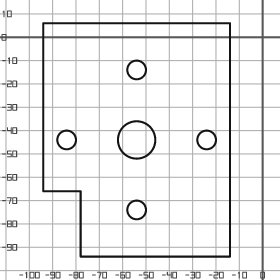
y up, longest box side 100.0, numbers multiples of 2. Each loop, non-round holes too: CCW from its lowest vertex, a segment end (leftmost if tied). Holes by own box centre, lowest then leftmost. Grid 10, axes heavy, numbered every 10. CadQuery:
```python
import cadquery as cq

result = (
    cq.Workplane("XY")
    .moveTo(-78.0, -94.0)
    .lineTo(-14.0, -94.0)
    .lineTo(-14.0, 6.0)
    .lineTo(-94.0, 6.0)
    .lineTo(-94.0, -66.0)
    .lineTo(-78.0, -66.0)
    .close()
    .moveTo(-54.0, -74.0)
    .circle(4.0)
    .moveTo(-84.0, -44.0)
    .circle(4.0)
    .moveTo(-54.0, -44.0)
    .circle(8.0)
    .moveTo(-24.0, -44.0)
    .circle(4.0)
    .moveTo(-54.0, -14.0)
    .circle(4.0)
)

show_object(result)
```